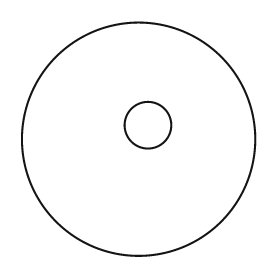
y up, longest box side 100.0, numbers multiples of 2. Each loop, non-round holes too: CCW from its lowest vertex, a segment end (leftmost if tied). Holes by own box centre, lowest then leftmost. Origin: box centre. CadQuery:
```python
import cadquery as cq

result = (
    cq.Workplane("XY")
    .moveTo(0.0, 0.0)
    .circle(50.0)
    .moveTo(4.0, 6.0)
    .circle(10.0)
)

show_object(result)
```